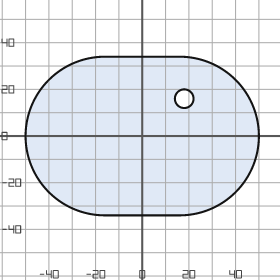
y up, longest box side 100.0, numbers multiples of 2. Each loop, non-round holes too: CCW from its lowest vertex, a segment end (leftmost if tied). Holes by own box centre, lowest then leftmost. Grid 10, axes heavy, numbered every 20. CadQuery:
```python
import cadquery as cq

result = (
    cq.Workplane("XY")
    .moveTo(-16.0, -34.0)
    .lineTo(16.0, -34.0)
    .threePointArc((50.0, 0.0), (16.0, 34.0))
    .lineTo(-16.0, 34.0)
    .threePointArc((-50.0, 0.0), (-16.0, -34.0))
    .close()
    .moveTo(18.0, 16.0)
    .circle(4.0)
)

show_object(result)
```